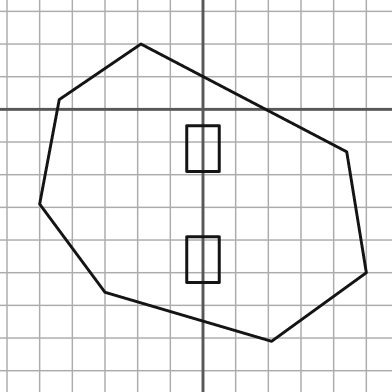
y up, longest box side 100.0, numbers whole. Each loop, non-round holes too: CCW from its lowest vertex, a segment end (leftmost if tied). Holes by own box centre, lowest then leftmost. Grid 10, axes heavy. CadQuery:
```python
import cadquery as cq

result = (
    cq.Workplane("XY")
    .moveTo(21.0, -71.0)
    .lineTo(50.0, -50.0)
    .lineTo(44.0, -13.0)
    .lineTo(-19.0, 20.0)
    .lineTo(-44.0, 3.0)
    .lineTo(-50.0, -29.0)
    .lineTo(-30.0, -56.0)
    .close()
    .moveTo(-5.0, -53.0)
    .lineTo(5.0, -53.0)
    .lineTo(5.0, -39.0)
    .lineTo(-5.0, -39.0)
    .close()
    .moveTo(-5.0, -19.0)
    .lineTo(5.0, -19.0)
    .lineTo(5.0, -5.0)
    .lineTo(-5.0, -5.0)
    .close()
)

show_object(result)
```